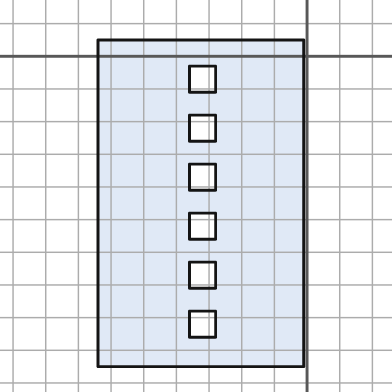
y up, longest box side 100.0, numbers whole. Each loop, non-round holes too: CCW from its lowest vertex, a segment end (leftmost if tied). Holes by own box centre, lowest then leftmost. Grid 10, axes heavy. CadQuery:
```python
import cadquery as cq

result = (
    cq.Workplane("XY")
    .moveTo(-64.0, -95.0)
    .lineTo(-1.0, -95.0)
    .lineTo(-1.0, 5.0)
    .lineTo(-64.0, 5.0)
    .close()
    .moveTo(-36.0, -86.0)
    .lineTo(-28.0, -86.0)
    .lineTo(-28.0, -78.0)
    .lineTo(-36.0, -78.0)
    .close()
    .moveTo(-36.0, -71.0)
    .lineTo(-28.0, -71.0)
    .lineTo(-28.0, -63.0)
    .lineTo(-36.0, -63.0)
    .close()
    .moveTo(-36.0, -56.0)
    .lineTo(-28.0, -56.0)
    .lineTo(-28.0, -48.0)
    .lineTo(-36.0, -48.0)
    .close()
    .moveTo(-36.0, -41.0)
    .lineTo(-28.0, -41.0)
    .lineTo(-28.0, -33.0)
    .lineTo(-36.0, -33.0)
    .close()
    .moveTo(-36.0, -26.0)
    .lineTo(-28.0, -26.0)
    .lineTo(-28.0, -18.0)
    .lineTo(-36.0, -18.0)
    .close()
    .moveTo(-36.0, -11.0)
    .lineTo(-28.0, -11.0)
    .lineTo(-28.0, -3.0)
    .lineTo(-36.0, -3.0)
    .close()
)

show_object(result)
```